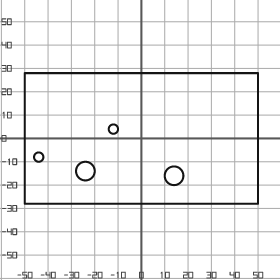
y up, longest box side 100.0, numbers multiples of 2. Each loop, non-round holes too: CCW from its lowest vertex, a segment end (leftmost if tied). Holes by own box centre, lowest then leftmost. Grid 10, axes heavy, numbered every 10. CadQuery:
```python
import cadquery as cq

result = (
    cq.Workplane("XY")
    .moveTo(-50.0, -28.0)
    .lineTo(50.0, -28.0)
    .lineTo(50.0, 28.0)
    .lineTo(-50.0, 28.0)
    .close()
    .moveTo(14.0, -16.0)
    .circle(4.0)
    .moveTo(-24.0, -14.0)
    .circle(4.0)
    .moveTo(-44.0, -8.0)
    .circle(2.0)
    .moveTo(-12.0, 4.0)
    .circle(2.0)
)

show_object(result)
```